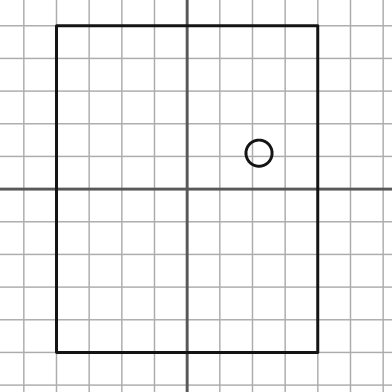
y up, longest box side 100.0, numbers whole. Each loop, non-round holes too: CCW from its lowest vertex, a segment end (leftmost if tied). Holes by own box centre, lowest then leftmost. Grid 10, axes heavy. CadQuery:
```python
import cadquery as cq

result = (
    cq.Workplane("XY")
    .moveTo(-40.0, -50.0)
    .lineTo(40.0, -50.0)
    .lineTo(40.0, 50.0)
    .lineTo(-40.0, 50.0)
    .close()
    .moveTo(22.0, 11.0)
    .circle(4.0)
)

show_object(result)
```